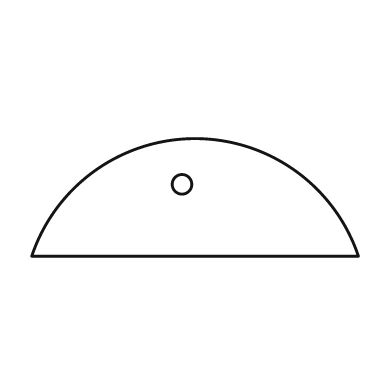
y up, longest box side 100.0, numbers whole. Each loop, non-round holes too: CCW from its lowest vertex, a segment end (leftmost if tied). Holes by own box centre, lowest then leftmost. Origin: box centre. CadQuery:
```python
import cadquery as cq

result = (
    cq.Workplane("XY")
    .moveTo(-50.0, -18.0)
    .lineTo(50.0, -18.0)
    .threePointArc((0.0, 18.0), (-50.0, -18.0))
    .close()
    .moveTo(-4.0, 4.0)
    .circle(3.0)
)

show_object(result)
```